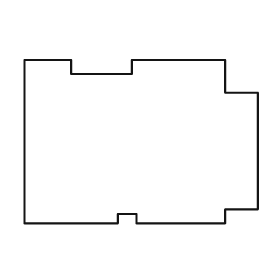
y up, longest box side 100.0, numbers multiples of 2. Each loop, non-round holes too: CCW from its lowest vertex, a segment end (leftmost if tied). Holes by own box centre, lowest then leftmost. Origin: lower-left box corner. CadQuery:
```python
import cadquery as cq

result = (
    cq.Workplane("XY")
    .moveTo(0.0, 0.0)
    .lineTo(40.0, 0.0)
    .lineTo(40.0, 4.0)
    .lineTo(48.0, 4.0)
    .lineTo(48.0, 0.0)
    .lineTo(86.0, 0.0)
    .lineTo(86.0, 6.0)
    .lineTo(100.0, 6.0)
    .lineTo(100.0, 56.0)
    .lineTo(86.0, 56.0)
    .lineTo(86.0, 70.0)
    .lineTo(46.0, 70.0)
    .lineTo(46.0, 64.0)
    .lineTo(20.0, 64.0)
    .lineTo(20.0, 70.0)
    .lineTo(0.0, 70.0)
    .close()
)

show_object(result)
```